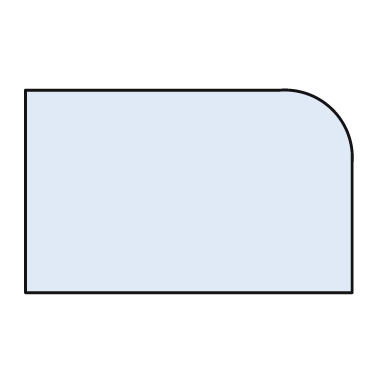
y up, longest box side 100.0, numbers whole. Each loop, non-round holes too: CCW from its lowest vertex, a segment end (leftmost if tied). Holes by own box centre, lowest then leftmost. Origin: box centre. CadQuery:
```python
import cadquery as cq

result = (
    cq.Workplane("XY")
    .moveTo(-50.0, -31.0)
    .lineTo(50.0, -31.0)
    .lineTo(50.0, 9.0)
    .threePointArc((44.0, 25.0), (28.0, 31.0))
    .lineTo(-50.0, 31.0)
    .close()
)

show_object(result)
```